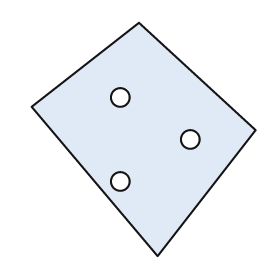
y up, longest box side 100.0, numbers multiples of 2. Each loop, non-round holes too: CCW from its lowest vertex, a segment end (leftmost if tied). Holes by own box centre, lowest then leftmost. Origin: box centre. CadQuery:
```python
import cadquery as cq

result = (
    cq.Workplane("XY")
    .moveTo(6.0, -50.0)
    .lineTo(48.0, 4.0)
    .lineTo(-2.0, 50.0)
    .lineTo(-48.0, 14.0)
    .close()
    .moveTo(-10.0, -18.0)
    .circle(4.0)
    .moveTo(20.0, 0.0)
    .circle(4.0)
    .moveTo(-10.0, 18.0)
    .circle(4.0)
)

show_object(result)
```